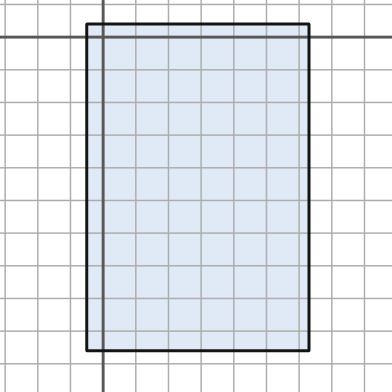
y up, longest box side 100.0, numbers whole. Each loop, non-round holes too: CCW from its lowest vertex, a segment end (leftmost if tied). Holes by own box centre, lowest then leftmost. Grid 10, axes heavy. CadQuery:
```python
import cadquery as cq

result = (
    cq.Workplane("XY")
    .moveTo(-5.0, -96.0)
    .lineTo(63.0, -96.0)
    .lineTo(63.0, 4.0)
    .lineTo(-5.0, 4.0)
    .close()
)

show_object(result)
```